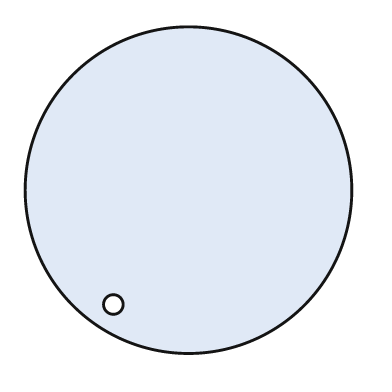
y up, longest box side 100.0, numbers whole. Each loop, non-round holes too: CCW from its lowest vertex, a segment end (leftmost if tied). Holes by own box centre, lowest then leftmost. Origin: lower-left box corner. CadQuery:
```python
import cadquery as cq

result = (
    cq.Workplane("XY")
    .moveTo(50.0, 50.0)
    .circle(50.0)
    .moveTo(27.0, 15.0)
    .circle(3.0)
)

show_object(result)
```